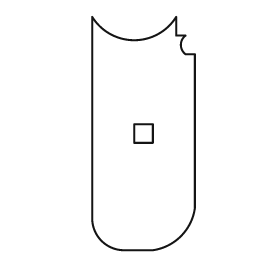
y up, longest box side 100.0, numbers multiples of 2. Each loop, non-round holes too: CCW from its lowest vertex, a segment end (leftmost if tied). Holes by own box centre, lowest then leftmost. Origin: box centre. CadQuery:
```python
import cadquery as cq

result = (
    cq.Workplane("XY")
    .moveTo(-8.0, -50.0)
    .lineTo(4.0, -50.0)
    .threePointArc((16.0, -44.0), (22.0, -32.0))
    .lineTo(22.0, 34.0)
    .lineTo(18.0, 34.0)
    .threePointArc((16.0, 38.0), (18.0, 42.0))
    .lineTo(14.0, 42.0)
    .lineTo(14.0, 50.0)
    .threePointArc((-4.0, 40.0), (-22.0, 50.0))
    .lineTo(-22.0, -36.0)
    .threePointArc((-18.0, -46.0), (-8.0, -50.0))
    .close()
    .moveTo(-4.0, -4.0)
    .lineTo(4.0, -4.0)
    .lineTo(4.0, 4.0)
    .lineTo(-4.0, 4.0)
    .close()
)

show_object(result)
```